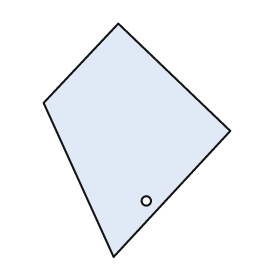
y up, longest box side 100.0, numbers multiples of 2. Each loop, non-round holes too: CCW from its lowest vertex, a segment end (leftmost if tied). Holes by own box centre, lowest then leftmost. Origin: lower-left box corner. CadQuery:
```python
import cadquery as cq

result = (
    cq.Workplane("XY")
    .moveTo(30.0, 0.0)
    .lineTo(80.0, 54.0)
    .lineTo(32.0, 100.0)
    .lineTo(0.0, 66.0)
    .close()
    .moveTo(44.0, 24.0)
    .circle(2.0)
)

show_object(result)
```